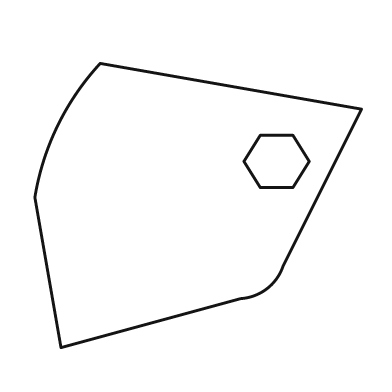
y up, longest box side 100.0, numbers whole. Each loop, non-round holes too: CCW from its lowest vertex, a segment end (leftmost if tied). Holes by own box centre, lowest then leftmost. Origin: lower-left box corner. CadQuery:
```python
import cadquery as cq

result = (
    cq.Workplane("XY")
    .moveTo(8.0, 0.0)
    .lineTo(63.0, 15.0)
    .threePointArc((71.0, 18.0), (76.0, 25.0))
    .lineTo(100.0, 73.0)
    .lineTo(20.0, 87.0)
    .threePointArc((7.0, 68.0), (0.0, 46.0))
    .close()
    .moveTo(69.0, 49.0)
    .lineTo(79.0, 49.0)
    .lineTo(84.0, 57.0)
    .lineTo(79.0, 65.0)
    .lineTo(69.0, 65.0)
    .lineTo(64.0, 57.0)
    .close()
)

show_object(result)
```